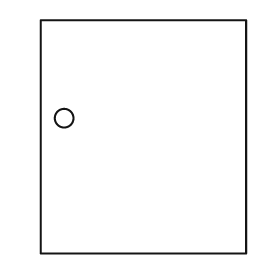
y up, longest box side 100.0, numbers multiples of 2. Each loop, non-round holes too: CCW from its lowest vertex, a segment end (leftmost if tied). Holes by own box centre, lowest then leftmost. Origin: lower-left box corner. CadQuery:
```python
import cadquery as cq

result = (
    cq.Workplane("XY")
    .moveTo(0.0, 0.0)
    .lineTo(88.0, 0.0)
    .lineTo(88.0, 100.0)
    .lineTo(0.0, 100.0)
    .close()
    .moveTo(10.0, 58.0)
    .circle(4.0)
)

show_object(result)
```